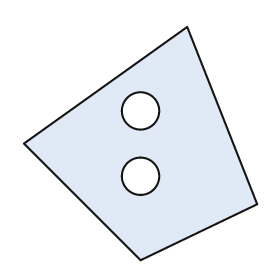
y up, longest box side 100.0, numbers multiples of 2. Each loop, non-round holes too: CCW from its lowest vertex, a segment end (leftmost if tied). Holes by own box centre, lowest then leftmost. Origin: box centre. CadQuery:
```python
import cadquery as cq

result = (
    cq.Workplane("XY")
    .moveTo(0.0, -50.0)
    .lineTo(50.0, -26.0)
    .lineTo(20.0, 50.0)
    .lineTo(-50.0, 0.0)
    .close()
    .moveTo(0.0, -14.0)
    .circle(8.0)
    .moveTo(0.0, 14.0)
    .circle(8.0)
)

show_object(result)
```